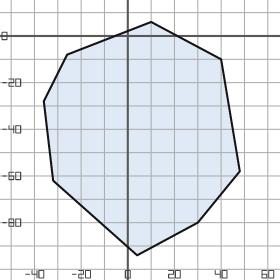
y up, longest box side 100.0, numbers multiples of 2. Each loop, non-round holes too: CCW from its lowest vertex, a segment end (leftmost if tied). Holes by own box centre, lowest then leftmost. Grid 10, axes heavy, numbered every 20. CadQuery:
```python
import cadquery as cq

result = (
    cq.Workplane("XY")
    .moveTo(4.0, -94.0)
    .lineTo(30.0, -80.0)
    .lineTo(48.0, -58.0)
    .lineTo(40.0, -10.0)
    .lineTo(10.0, 6.0)
    .lineTo(-26.0, -8.0)
    .lineTo(-36.0, -28.0)
    .lineTo(-32.0, -62.0)
    .close()
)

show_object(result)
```